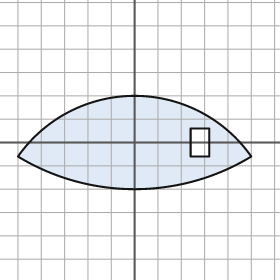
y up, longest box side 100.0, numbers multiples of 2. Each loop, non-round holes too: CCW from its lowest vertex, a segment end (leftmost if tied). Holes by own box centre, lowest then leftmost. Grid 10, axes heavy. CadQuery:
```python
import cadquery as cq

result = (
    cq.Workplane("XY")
    .moveTo(-50.0, -6.0)
    .threePointArc((0.0, -20.0), (50.0, -6.0))
    .threePointArc((0.0, 20.0), (-50.0, -6.0))
    .close()
    .moveTo(24.0, -6.0)
    .lineTo(32.0, -6.0)
    .lineTo(32.0, 6.0)
    .lineTo(24.0, 6.0)
    .close()
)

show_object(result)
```